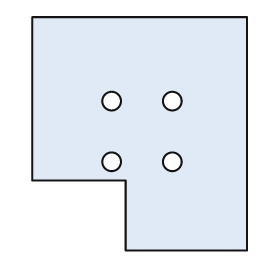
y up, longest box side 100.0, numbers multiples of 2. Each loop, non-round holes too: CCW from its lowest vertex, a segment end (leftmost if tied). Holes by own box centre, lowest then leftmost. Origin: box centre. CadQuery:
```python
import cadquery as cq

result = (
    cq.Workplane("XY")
    .moveTo(-6.0, -50.0)
    .lineTo(46.0, -50.0)
    .lineTo(46.0, 50.0)
    .lineTo(-46.0, 50.0)
    .lineTo(-46.0, -20.0)
    .lineTo(-6.0, -20.0)
    .close()
    .moveTo(-12.0, -12.0)
    .circle(4.0)
    .moveTo(14.0, -12.0)
    .circle(4.0)
    .moveTo(-12.0, 14.0)
    .circle(4.0)
    .moveTo(14.0, 14.0)
    .circle(4.0)
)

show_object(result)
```